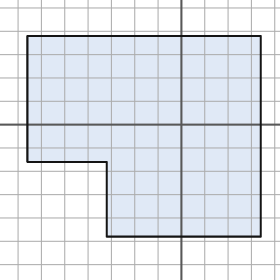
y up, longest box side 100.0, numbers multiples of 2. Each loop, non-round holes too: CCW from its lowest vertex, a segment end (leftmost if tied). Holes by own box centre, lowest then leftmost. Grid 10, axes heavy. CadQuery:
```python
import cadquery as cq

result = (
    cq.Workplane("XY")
    .moveTo(-32.0, -48.0)
    .lineTo(34.0, -48.0)
    .lineTo(34.0, 38.0)
    .lineTo(-66.0, 38.0)
    .lineTo(-66.0, -16.0)
    .lineTo(-32.0, -16.0)
    .close()
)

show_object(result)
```